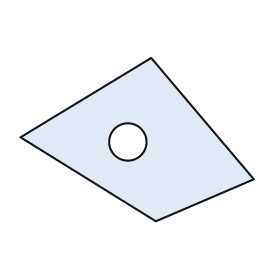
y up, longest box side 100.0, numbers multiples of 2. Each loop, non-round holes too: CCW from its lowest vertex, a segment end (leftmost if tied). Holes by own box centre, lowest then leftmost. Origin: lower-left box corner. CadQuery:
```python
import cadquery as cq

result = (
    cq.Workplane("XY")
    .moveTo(58.0, 0.0)
    .lineTo(100.0, 18.0)
    .lineTo(56.0, 70.0)
    .lineTo(0.0, 36.0)
    .close()
    .moveTo(46.0, 34.0)
    .circle(8.0)
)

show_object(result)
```